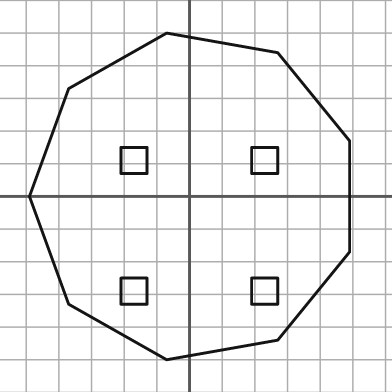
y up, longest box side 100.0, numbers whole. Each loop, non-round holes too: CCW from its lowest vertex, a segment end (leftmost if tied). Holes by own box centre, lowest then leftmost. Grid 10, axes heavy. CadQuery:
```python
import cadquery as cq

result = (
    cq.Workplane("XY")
    .moveTo(-7.0, -50.0)
    .lineTo(27.0, -44.0)
    .lineTo(49.0, -17.0)
    .lineTo(49.0, 17.0)
    .lineTo(27.0, 44.0)
    .lineTo(-7.0, 50.0)
    .lineTo(-37.0, 33.0)
    .lineTo(-49.0, 0.0)
    .lineTo(-37.0, -33.0)
    .close()
    .moveTo(-21.0, -33.0)
    .lineTo(-13.0, -33.0)
    .lineTo(-13.0, -25.0)
    .lineTo(-21.0, -25.0)
    .close()
    .moveTo(19.0, -33.0)
    .lineTo(27.0, -33.0)
    .lineTo(27.0, -25.0)
    .lineTo(19.0, -25.0)
    .close()
    .moveTo(-21.0, 7.0)
    .lineTo(-13.0, 7.0)
    .lineTo(-13.0, 15.0)
    .lineTo(-21.0, 15.0)
    .close()
    .moveTo(19.0, 7.0)
    .lineTo(27.0, 7.0)
    .lineTo(27.0, 15.0)
    .lineTo(19.0, 15.0)
    .close()
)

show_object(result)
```